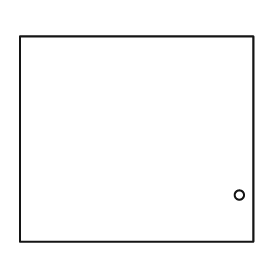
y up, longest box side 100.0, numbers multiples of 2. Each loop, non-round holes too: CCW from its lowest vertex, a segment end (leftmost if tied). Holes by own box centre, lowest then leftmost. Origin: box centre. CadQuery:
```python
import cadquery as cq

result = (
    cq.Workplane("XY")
    .moveTo(-50.0, -44.0)
    .lineTo(50.0, -44.0)
    .lineTo(50.0, 44.0)
    .lineTo(-50.0, 44.0)
    .close()
    .moveTo(44.0, -24.0)
    .circle(2.0)
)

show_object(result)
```